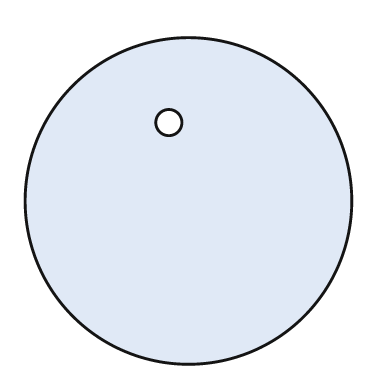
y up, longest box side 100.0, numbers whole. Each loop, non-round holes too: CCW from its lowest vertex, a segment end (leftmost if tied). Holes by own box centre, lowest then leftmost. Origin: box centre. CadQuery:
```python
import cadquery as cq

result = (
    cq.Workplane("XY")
    .moveTo(0.0, 0.0)
    .circle(50.0)
    .moveTo(-6.0, 24.0)
    .circle(4.0)
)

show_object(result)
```